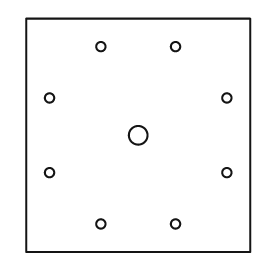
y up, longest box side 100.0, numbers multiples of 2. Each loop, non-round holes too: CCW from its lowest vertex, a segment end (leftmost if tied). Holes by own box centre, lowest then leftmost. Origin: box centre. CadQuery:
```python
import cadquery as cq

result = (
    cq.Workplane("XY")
    .moveTo(-48.0, -50.0)
    .lineTo(48.0, -50.0)
    .lineTo(48.0, 50.0)
    .lineTo(-48.0, 50.0)
    .close()
    .moveTo(-16.0, -38.0)
    .circle(2.0)
    .moveTo(16.0, -38.0)
    .circle(2.0)
    .moveTo(-38.0, -16.0)
    .circle(2.0)
    .moveTo(38.0, -16.0)
    .circle(2.0)
    .moveTo(0.0, 0.0)
    .circle(4.0)
    .moveTo(-38.0, 16.0)
    .circle(2.0)
    .moveTo(38.0, 16.0)
    .circle(2.0)
    .moveTo(-16.0, 38.0)
    .circle(2.0)
    .moveTo(16.0, 38.0)
    .circle(2.0)
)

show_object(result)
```